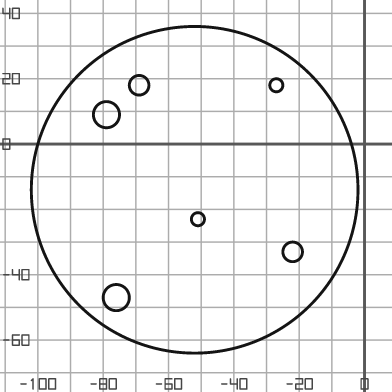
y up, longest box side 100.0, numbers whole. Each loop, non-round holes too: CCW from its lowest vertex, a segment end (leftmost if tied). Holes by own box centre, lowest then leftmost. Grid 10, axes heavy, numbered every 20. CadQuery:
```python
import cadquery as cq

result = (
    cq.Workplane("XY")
    .moveTo(-52.0, -14.0)
    .circle(50.0)
    .moveTo(-76.0, -47.0)
    .circle(4.0)
    .moveTo(-22.0, -33.0)
    .circle(3.0)
    .moveTo(-51.0, -23.0)
    .circle(2.0)
    .moveTo(-79.0, 9.0)
    .circle(4.0)
    .moveTo(-69.0, 18.0)
    .circle(3.0)
    .moveTo(-27.0, 18.0)
    .circle(2.0)
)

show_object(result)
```